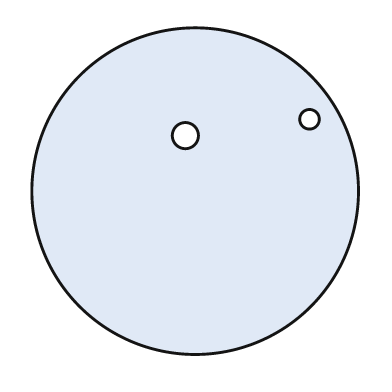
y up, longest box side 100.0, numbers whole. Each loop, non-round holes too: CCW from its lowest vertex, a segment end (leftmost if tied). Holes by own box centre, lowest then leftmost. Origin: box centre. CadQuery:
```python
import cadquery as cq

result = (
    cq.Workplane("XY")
    .moveTo(0.0, 0.0)
    .circle(50.0)
    .moveTo(-3.0, 17.0)
    .circle(4.0)
    .moveTo(35.0, 22.0)
    .circle(3.0)
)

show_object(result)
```